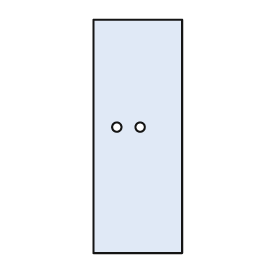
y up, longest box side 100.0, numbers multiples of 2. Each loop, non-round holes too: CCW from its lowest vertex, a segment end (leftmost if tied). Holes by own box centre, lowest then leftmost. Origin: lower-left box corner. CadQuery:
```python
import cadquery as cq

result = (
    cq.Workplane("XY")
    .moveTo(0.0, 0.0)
    .lineTo(38.0, 0.0)
    .lineTo(38.0, 100.0)
    .lineTo(0.0, 100.0)
    .close()
    .moveTo(10.0, 54.0)
    .circle(2.0)
    .moveTo(20.0, 54.0)
    .circle(2.0)
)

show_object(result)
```